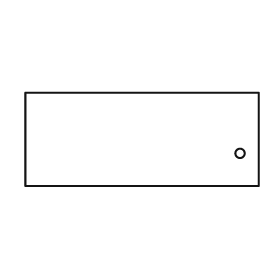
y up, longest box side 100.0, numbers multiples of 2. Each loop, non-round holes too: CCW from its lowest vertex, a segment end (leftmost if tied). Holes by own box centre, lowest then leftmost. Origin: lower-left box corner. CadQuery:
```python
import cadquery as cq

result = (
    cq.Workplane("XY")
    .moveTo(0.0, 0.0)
    .lineTo(100.0, 0.0)
    .lineTo(100.0, 40.0)
    .lineTo(0.0, 40.0)
    .close()
    .moveTo(92.0, 14.0)
    .circle(2.0)
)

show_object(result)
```